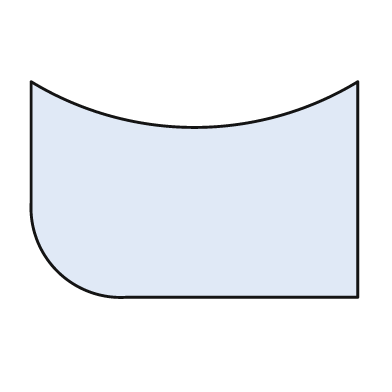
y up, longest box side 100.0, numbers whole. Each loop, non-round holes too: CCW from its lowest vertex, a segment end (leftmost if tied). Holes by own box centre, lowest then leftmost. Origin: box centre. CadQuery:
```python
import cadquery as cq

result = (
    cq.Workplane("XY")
    .moveTo(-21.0, -33.0)
    .lineTo(50.0, -33.0)
    .lineTo(50.0, 33.0)
    .threePointArc((0.0, 19.0), (-50.0, 33.0))
    .lineTo(-50.0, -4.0)
    .threePointArc((-42.0, -25.0), (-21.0, -33.0))
    .close()
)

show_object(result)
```